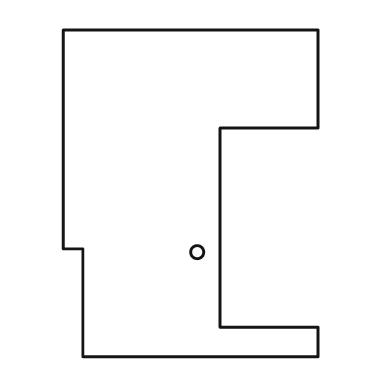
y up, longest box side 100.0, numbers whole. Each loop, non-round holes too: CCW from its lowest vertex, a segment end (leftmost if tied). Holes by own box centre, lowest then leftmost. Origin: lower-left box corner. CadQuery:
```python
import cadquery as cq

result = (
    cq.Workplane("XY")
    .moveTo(6.0, 0.0)
    .lineTo(78.0, 0.0)
    .lineTo(78.0, 9.0)
    .lineTo(48.0, 9.0)
    .lineTo(48.0, 70.0)
    .lineTo(78.0, 70.0)
    .lineTo(78.0, 100.0)
    .lineTo(0.0, 100.0)
    .lineTo(0.0, 33.0)
    .lineTo(6.0, 33.0)
    .close()
    .moveTo(41.0, 32.0)
    .circle(2.0)
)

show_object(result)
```